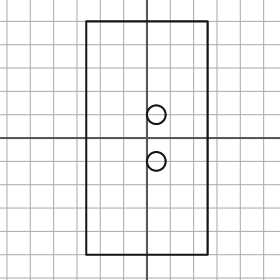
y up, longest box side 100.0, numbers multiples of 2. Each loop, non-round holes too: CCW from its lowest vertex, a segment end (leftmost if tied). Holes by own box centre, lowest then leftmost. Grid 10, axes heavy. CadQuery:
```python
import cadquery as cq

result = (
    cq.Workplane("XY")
    .moveTo(-26.0, -50.0)
    .lineTo(26.0, -50.0)
    .lineTo(26.0, 50.0)
    .lineTo(-26.0, 50.0)
    .close()
    .moveTo(4.0, -10.0)
    .circle(4.0)
    .moveTo(4.0, 10.0)
    .circle(4.0)
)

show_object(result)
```